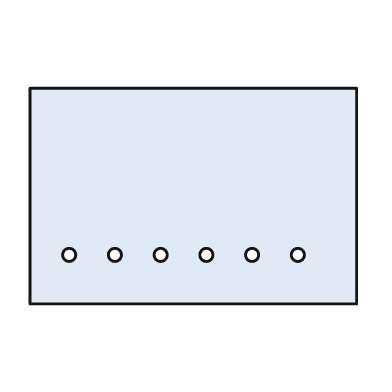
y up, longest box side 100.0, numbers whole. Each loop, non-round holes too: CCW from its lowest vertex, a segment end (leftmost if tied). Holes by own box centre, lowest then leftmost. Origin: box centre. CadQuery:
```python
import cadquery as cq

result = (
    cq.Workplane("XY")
    .moveTo(-50.0, -33.0)
    .lineTo(50.0, -33.0)
    .lineTo(50.0, 33.0)
    .lineTo(-50.0, 33.0)
    .close()
    .moveTo(-38.0, -18.0)
    .circle(2.0)
    .moveTo(-24.0, -18.0)
    .circle(2.0)
    .moveTo(-10.0, -18.0)
    .circle(2.0)
    .moveTo(4.0, -18.0)
    .circle(2.0)
    .moveTo(18.0, -18.0)
    .circle(2.0)
    .moveTo(32.0, -18.0)
    .circle(2.0)
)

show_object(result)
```